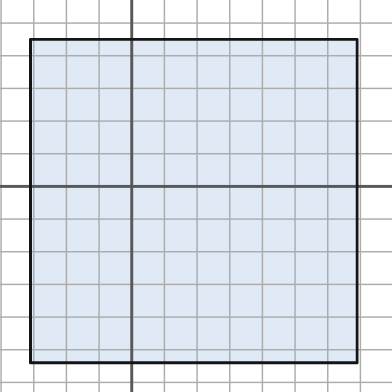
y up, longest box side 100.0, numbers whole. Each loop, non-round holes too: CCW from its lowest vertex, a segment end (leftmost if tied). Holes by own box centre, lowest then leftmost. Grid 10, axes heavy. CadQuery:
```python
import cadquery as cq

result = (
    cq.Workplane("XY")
    .moveTo(-31.0, -54.0)
    .lineTo(69.0, -54.0)
    .lineTo(69.0, 45.0)
    .lineTo(-31.0, 45.0)
    .close()
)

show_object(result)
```